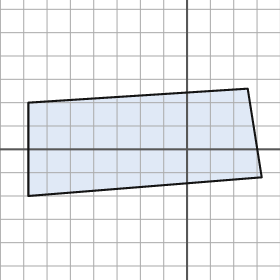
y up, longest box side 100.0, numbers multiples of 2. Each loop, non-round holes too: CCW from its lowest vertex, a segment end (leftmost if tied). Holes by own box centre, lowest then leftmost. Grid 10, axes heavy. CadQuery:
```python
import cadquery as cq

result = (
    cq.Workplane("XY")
    .moveTo(-68.0, -20.0)
    .lineTo(32.0, -12.0)
    .lineTo(26.0, 26.0)
    .lineTo(-68.0, 20.0)
    .close()
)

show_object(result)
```